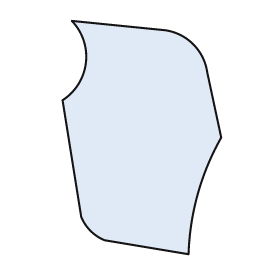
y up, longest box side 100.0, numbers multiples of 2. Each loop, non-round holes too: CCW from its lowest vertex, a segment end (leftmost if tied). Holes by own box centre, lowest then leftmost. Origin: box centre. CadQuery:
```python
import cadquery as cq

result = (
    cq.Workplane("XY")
    .moveTo(20.0, -50.0)
    .threePointArc((24.0, -24.0), (34.0, 0.0))
    .lineTo(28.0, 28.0)
    .threePointArc((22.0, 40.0), (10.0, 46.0))
    .lineTo(-30.0, 50.0)
    .threePointArc((-24.0, 32.0), (-34.0, 16.0))
    .lineTo(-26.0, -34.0)
    .threePointArc((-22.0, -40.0), (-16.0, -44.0))
    .close()
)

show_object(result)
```